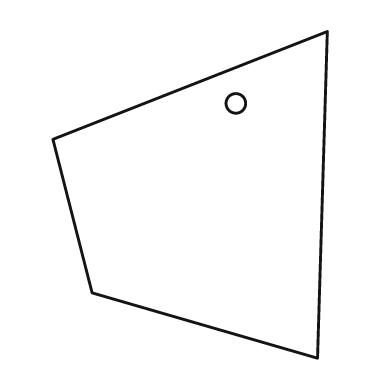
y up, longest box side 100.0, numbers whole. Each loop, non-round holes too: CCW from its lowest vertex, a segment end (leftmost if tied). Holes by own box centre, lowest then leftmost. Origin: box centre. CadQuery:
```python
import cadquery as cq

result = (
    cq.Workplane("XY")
    .moveTo(39.0, -50.0)
    .lineTo(42.0, 50.0)
    .lineTo(-42.0, 17.0)
    .lineTo(-30.0, -30.0)
    .close()
    .moveTo(14.0, 28.0)
    .circle(3.0)
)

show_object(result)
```